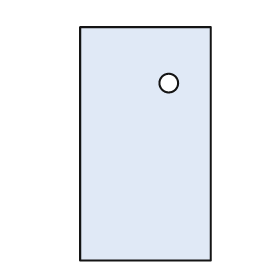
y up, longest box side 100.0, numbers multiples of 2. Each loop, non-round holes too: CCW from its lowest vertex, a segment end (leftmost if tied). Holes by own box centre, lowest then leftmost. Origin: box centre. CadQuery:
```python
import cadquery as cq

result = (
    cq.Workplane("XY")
    .moveTo(-28.0, -50.0)
    .lineTo(28.0, -50.0)
    .lineTo(28.0, 50.0)
    .lineTo(-28.0, 50.0)
    .close()
    .moveTo(10.0, 26.0)
    .circle(4.0)
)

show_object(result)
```